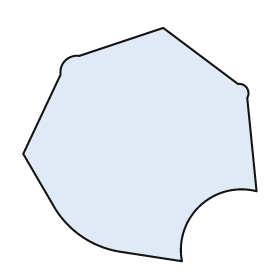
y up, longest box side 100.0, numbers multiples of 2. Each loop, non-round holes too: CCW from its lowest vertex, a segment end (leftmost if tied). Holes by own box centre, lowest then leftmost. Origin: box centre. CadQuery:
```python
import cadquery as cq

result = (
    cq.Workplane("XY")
    .moveTo(18.0, -50.0)
    .threePointArc((26.0, -26.0), (50.0, -20.0))
    .lineTo(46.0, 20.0)
    .threePointArc((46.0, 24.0), (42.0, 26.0))
    .lineTo(10.0, 50.0)
    .lineTo(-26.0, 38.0)
    .threePointArc((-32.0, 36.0), (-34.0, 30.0))
    .lineTo(-50.0, -4.0)
    .lineTo(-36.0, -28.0)
    .threePointArc((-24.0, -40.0), (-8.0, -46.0))
    .close()
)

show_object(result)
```